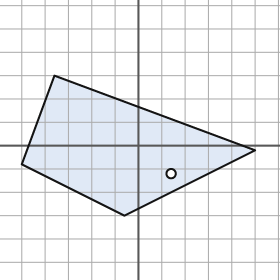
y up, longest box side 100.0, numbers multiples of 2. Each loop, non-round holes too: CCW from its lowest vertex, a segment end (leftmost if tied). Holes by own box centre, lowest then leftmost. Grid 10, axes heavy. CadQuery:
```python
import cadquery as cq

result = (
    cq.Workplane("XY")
    .moveTo(-6.0, -30.0)
    .lineTo(50.0, -2.0)
    .lineTo(-36.0, 30.0)
    .lineTo(-50.0, -8.0)
    .close()
    .moveTo(14.0, -12.0)
    .circle(2.0)
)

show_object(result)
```